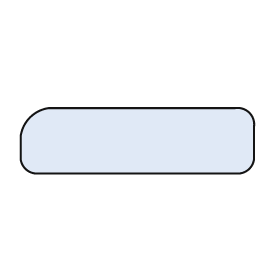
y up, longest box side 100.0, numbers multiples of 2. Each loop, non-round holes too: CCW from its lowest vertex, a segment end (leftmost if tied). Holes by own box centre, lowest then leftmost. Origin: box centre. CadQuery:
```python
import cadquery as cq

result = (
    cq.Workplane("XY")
    .moveTo(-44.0, -14.0)
    .lineTo(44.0, -14.0)
    .threePointArc((48.0, -12.0), (50.0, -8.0))
    .lineTo(50.0, 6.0)
    .threePointArc((48.0, 12.0), (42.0, 14.0))
    .lineTo(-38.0, 14.0)
    .threePointArc((-46.0, 10.0), (-50.0, 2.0))
    .lineTo(-50.0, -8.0)
    .threePointArc((-48.0, -12.0), (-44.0, -14.0))
    .close()
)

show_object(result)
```